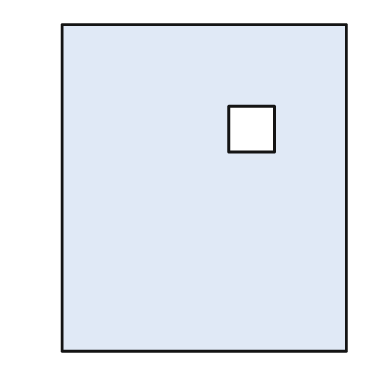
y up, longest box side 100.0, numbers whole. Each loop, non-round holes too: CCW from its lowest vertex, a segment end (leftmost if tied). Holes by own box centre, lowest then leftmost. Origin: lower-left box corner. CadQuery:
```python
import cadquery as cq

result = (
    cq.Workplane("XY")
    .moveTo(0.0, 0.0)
    .lineTo(87.0, 0.0)
    .lineTo(87.0, 100.0)
    .lineTo(0.0, 100.0)
    .close()
    .moveTo(51.0, 61.0)
    .lineTo(65.0, 61.0)
    .lineTo(65.0, 75.0)
    .lineTo(51.0, 75.0)
    .close()
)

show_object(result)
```